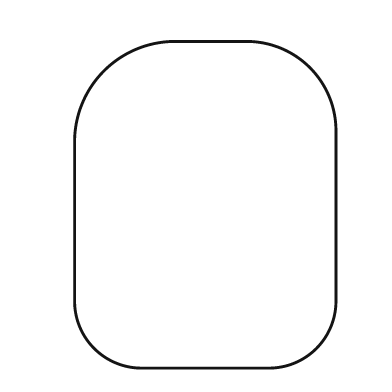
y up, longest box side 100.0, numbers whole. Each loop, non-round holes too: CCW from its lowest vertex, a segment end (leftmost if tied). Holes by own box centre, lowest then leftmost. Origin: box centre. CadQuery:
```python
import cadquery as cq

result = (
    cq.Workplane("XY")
    .moveTo(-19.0, -50.0)
    .lineTo(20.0, -50.0)
    .threePointArc((34.0, -44.0), (40.0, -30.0))
    .lineTo(40.0, 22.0)
    .threePointArc((32.0, 42.0), (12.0, 50.0))
    .lineTo(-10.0, 50.0)
    .threePointArc((-31.0, 41.0), (-40.0, 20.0))
    .lineTo(-40.0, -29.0)
    .threePointArc((-34.0, -44.0), (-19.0, -50.0))
    .close()
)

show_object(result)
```